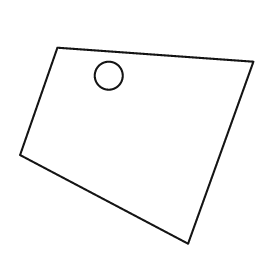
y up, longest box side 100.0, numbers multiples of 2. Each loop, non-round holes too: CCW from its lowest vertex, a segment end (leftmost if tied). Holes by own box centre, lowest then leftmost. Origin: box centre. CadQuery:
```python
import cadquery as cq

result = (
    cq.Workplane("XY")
    .moveTo(22.0, -42.0)
    .lineTo(50.0, 36.0)
    .lineTo(-34.0, 42.0)
    .lineTo(-50.0, -4.0)
    .close()
    .moveTo(-12.0, 30.0)
    .circle(6.0)
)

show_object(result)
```